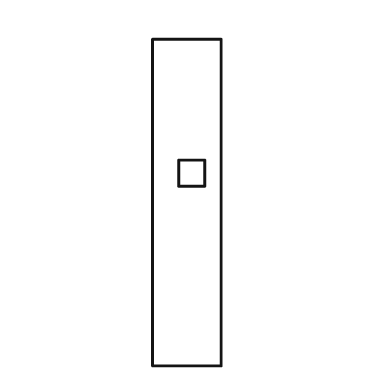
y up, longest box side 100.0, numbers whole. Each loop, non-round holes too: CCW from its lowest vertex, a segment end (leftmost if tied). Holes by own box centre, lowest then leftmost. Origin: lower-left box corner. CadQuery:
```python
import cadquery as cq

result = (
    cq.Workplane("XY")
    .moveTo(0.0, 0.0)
    .lineTo(21.0, 0.0)
    .lineTo(21.0, 100.0)
    .lineTo(0.0, 100.0)
    .close()
    .moveTo(8.0, 55.0)
    .lineTo(16.0, 55.0)
    .lineTo(16.0, 63.0)
    .lineTo(8.0, 63.0)
    .close()
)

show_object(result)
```